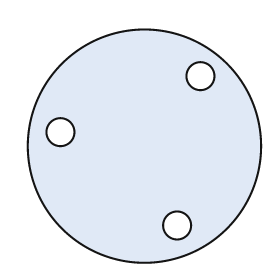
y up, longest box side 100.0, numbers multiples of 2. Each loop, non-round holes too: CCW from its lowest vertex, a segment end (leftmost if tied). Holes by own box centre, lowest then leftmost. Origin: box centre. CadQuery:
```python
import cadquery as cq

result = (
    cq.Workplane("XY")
    .moveTo(0.0, 0.0)
    .circle(50.0)
    .moveTo(14.0, -34.0)
    .circle(6.0)
    .moveTo(-36.0, 6.0)
    .circle(6.0)
    .moveTo(24.0, 30.0)
    .circle(6.0)
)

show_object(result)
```